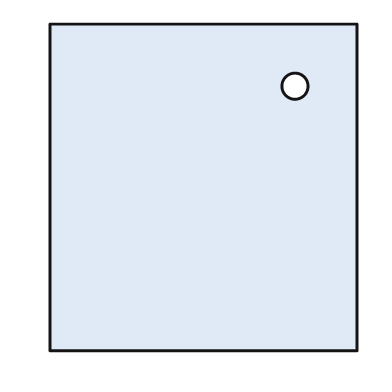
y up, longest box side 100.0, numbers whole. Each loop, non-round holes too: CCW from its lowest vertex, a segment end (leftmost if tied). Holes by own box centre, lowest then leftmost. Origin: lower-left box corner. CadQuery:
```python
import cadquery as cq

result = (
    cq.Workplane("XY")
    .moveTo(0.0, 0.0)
    .lineTo(94.0, 0.0)
    .lineTo(94.0, 100.0)
    .lineTo(0.0, 100.0)
    .close()
    .moveTo(75.0, 81.0)
    .circle(4.0)
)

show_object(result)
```